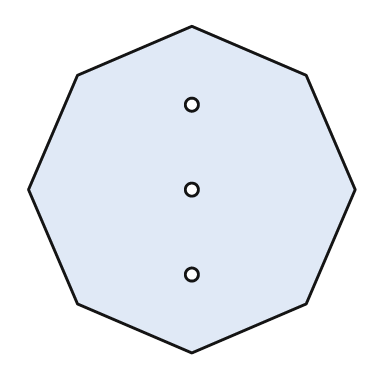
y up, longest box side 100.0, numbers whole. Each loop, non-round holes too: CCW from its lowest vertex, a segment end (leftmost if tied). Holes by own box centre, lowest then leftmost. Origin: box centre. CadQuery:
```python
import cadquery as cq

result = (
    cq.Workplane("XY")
    .moveTo(0.0, -50.0)
    .lineTo(35.0, -35.0)
    .lineTo(50.0, 0.0)
    .lineTo(35.0, 35.0)
    .lineTo(0.0, 50.0)
    .lineTo(-35.0, 35.0)
    .lineTo(-50.0, 0.0)
    .lineTo(-35.0, -35.0)
    .close()
    .moveTo(0.0, -26.0)
    .circle(2.0)
    .moveTo(0.0, 0.0)
    .circle(2.0)
    .moveTo(0.0, 26.0)
    .circle(2.0)
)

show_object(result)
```